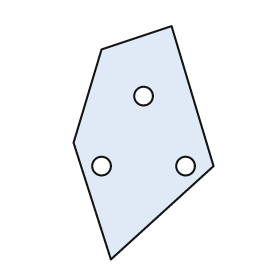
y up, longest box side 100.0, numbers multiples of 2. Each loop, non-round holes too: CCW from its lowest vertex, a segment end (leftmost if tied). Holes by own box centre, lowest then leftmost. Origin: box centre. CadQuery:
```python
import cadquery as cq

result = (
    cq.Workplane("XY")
    .moveTo(-14.0, -50.0)
    .lineTo(30.0, -10.0)
    .lineTo(12.0, 50.0)
    .lineTo(-18.0, 40.0)
    .lineTo(-30.0, 0.0)
    .close()
    .moveTo(-18.0, -10.0)
    .circle(4.0)
    .moveTo(18.0, -10.0)
    .circle(4.0)
    .moveTo(0.0, 20.0)
    .circle(4.0)
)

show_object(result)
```